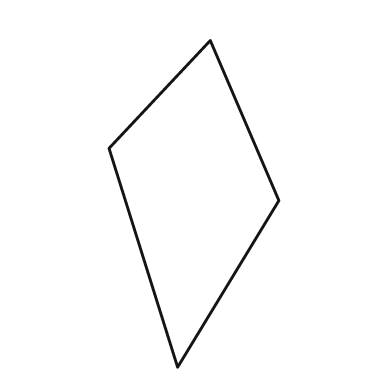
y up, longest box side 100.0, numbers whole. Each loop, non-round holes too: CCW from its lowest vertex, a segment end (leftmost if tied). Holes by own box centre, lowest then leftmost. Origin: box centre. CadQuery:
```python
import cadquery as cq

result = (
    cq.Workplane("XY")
    .moveTo(-5.0, -50.0)
    .lineTo(26.0, 1.0)
    .lineTo(5.0, 50.0)
    .lineTo(-26.0, 17.0)
    .close()
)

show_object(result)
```